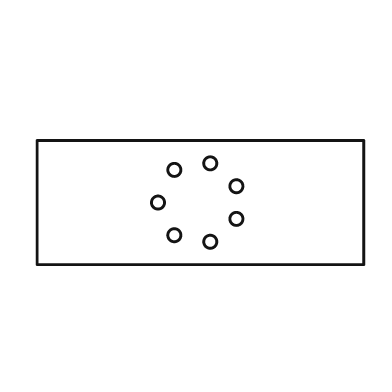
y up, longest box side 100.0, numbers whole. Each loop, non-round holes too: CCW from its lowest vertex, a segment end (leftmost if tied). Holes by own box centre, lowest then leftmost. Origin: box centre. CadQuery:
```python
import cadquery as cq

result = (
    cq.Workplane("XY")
    .moveTo(-50.0, -19.0)
    .lineTo(50.0, -19.0)
    .lineTo(50.0, 19.0)
    .lineTo(-50.0, 19.0)
    .close()
    .moveTo(3.0, -12.0)
    .circle(2.0)
    .moveTo(-8.0, -10.0)
    .circle(2.0)
    .moveTo(11.0, -5.0)
    .circle(2.0)
    .moveTo(-13.0, 0.0)
    .circle(2.0)
    .moveTo(11.0, 5.0)
    .circle(2.0)
    .moveTo(-8.0, 10.0)
    .circle(2.0)
    .moveTo(3.0, 12.0)
    .circle(2.0)
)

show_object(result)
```